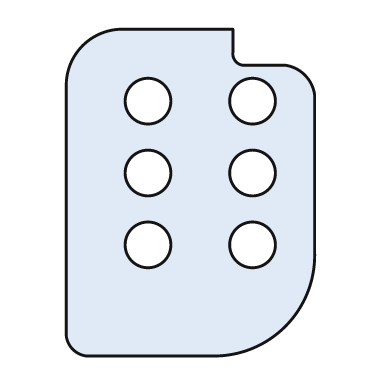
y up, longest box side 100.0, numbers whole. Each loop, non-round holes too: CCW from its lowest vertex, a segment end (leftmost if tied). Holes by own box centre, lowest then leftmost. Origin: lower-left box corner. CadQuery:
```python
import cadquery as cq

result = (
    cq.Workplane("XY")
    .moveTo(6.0, 0.0)
    .lineTo(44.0, 0.0)
    .threePointArc((67.0, 9.0), (76.0, 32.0))
    .lineTo(76.0, 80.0)
    .threePointArc((73.0, 86.0), (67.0, 89.0))
    .lineTo(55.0, 89.0)
    .threePointArc((52.0, 90.0), (51.0, 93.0))
    .lineTo(51.0, 100.0)
    .lineTo(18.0, 100.0)
    .threePointArc((5.0, 95.0), (0.0, 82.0))
    .lineTo(0.0, 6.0)
    .threePointArc((2.0, 2.0), (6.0, 0.0))
    .close()
    .moveTo(25.0, 34.0)
    .circle(7.0)
    .moveTo(57.0, 34.0)
    .circle(7.0)
    .moveTo(25.0, 56.0)
    .circle(7.0)
    .moveTo(57.0, 56.0)
    .circle(7.0)
    .moveTo(25.0, 78.0)
    .circle(7.0)
    .moveTo(57.0, 78.0)
    .circle(7.0)
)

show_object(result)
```